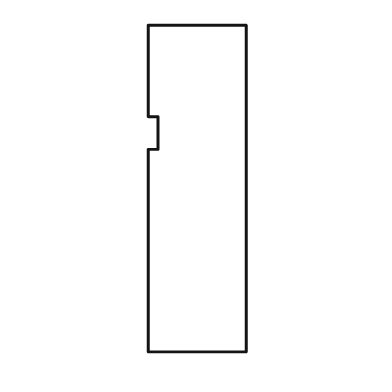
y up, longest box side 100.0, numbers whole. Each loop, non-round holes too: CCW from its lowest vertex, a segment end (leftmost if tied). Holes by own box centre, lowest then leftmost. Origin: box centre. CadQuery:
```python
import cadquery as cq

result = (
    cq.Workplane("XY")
    .moveTo(-15.0, -50.0)
    .lineTo(15.0, -50.0)
    .lineTo(15.0, 50.0)
    .lineTo(-15.0, 50.0)
    .lineTo(-15.0, 22.0)
    .lineTo(-12.0, 22.0)
    .lineTo(-12.0, 12.0)
    .lineTo(-15.0, 12.0)
    .close()
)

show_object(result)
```